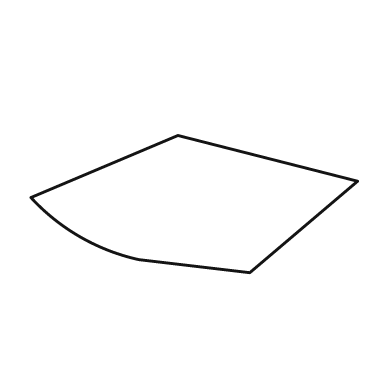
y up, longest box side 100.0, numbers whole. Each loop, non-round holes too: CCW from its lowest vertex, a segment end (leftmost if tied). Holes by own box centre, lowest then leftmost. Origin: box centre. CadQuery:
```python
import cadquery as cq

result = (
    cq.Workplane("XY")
    .moveTo(17.0, -21.0)
    .lineTo(50.0, 7.0)
    .lineTo(-5.0, 21.0)
    .lineTo(-50.0, 2.0)
    .threePointArc((-35.0, -10.0), (-17.0, -17.0))
    .close()
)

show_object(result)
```